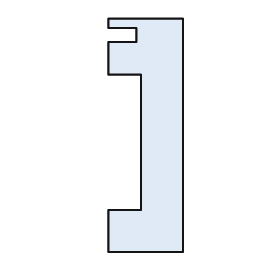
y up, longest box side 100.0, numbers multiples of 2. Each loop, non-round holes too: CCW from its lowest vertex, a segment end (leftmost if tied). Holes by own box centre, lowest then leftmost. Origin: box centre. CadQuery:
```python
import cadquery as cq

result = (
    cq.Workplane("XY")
    .moveTo(-16.0, -50.0)
    .lineTo(16.0, -50.0)
    .lineTo(16.0, 50.0)
    .lineTo(-16.0, 50.0)
    .lineTo(-16.0, 46.0)
    .lineTo(-4.0, 46.0)
    .lineTo(-4.0, 40.0)
    .lineTo(-16.0, 40.0)
    .lineTo(-16.0, 26.0)
    .lineTo(-2.0, 26.0)
    .lineTo(-2.0, -32.0)
    .lineTo(-16.0, -32.0)
    .close()
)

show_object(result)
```